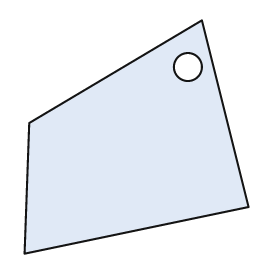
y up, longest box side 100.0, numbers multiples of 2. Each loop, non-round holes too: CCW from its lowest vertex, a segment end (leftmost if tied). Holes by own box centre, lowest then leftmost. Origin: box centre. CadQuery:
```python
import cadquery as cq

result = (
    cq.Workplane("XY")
    .moveTo(-48.0, -50.0)
    .lineTo(48.0, -30.0)
    .lineTo(28.0, 50.0)
    .lineTo(-46.0, 6.0)
    .close()
    .moveTo(22.0, 30.0)
    .circle(6.0)
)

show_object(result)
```